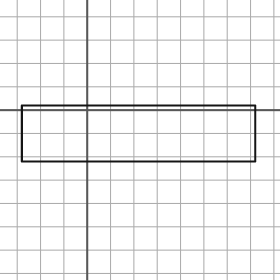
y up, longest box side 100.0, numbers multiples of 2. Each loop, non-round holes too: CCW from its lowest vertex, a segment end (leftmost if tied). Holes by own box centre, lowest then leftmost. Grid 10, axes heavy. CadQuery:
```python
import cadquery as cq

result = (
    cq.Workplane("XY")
    .moveTo(-28.0, -22.0)
    .lineTo(72.0, -22.0)
    .lineTo(72.0, 2.0)
    .lineTo(-28.0, 2.0)
    .close()
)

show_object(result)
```